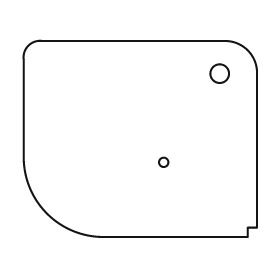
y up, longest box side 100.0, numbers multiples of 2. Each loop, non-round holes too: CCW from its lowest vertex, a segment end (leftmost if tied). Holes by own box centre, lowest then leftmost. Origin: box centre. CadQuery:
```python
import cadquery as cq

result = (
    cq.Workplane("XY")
    .moveTo(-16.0, -42.0)
    .lineTo(46.0, -42.0)
    .lineTo(46.0, -38.0)
    .lineTo(50.0, -38.0)
    .lineTo(50.0, 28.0)
    .threePointArc((46.0, 38.0), (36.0, 42.0))
    .lineTo(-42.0, 42.0)
    .threePointArc((-48.0, 40.0), (-50.0, 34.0))
    .lineTo(-50.0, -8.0)
    .threePointArc((-40.0, -32.0), (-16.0, -42.0))
    .close()
    .moveTo(10.0, -10.0)
    .circle(2.0)
    .moveTo(34.0, 28.0)
    .circle(4.0)
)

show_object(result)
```